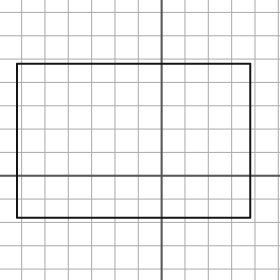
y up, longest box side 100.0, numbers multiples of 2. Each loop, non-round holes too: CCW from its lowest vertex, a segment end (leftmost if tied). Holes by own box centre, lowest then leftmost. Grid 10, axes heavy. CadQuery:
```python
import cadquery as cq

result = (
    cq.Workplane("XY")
    .moveTo(-62.0, -18.0)
    .lineTo(38.0, -18.0)
    .lineTo(38.0, 48.0)
    .lineTo(-62.0, 48.0)
    .close()
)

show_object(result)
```